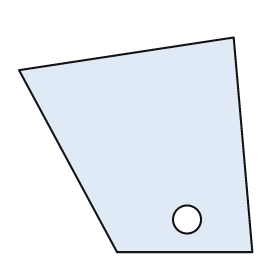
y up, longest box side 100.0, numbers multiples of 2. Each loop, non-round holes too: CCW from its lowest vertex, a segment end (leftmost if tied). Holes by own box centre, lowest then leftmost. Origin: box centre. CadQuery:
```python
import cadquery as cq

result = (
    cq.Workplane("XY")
    .moveTo(-8.0, -46.0)
    .lineTo(50.0, -46.0)
    .lineTo(42.0, 46.0)
    .lineTo(-50.0, 32.0)
    .close()
    .moveTo(22.0, -32.0)
    .circle(6.0)
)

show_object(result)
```